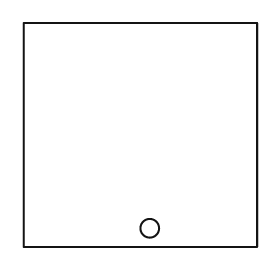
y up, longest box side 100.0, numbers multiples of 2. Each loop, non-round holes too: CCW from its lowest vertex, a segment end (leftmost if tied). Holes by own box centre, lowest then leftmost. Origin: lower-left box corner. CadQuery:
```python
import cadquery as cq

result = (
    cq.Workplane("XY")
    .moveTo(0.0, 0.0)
    .lineTo(100.0, 0.0)
    .lineTo(100.0, 96.0)
    .lineTo(0.0, 96.0)
    .close()
    .moveTo(54.0, 8.0)
    .circle(4.0)
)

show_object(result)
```